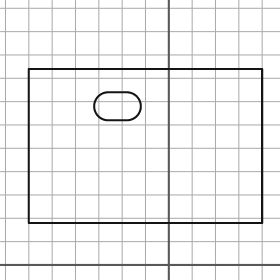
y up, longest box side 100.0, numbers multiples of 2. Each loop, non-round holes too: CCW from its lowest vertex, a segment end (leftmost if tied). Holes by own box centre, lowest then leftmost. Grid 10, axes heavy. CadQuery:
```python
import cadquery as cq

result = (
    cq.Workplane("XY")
    .moveTo(-60.0, 18.0)
    .lineTo(40.0, 18.0)
    .lineTo(40.0, 84.0)
    .lineTo(-60.0, 84.0)
    .close()
    .moveTo(-26.0, 62.0)
    .lineTo(-18.0, 62.0)
    .threePointArc((-12.0, 68.0), (-18.0, 74.0))
    .lineTo(-26.0, 74.0)
    .threePointArc((-32.0, 68.0), (-26.0, 62.0))
    .close()
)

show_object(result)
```